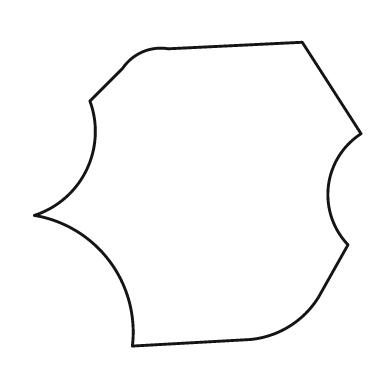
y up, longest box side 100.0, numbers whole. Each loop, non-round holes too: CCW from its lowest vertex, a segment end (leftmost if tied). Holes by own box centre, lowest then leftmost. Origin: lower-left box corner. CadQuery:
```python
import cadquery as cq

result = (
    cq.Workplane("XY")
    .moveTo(30.0, 0.0)
    .lineTo(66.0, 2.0)
    .threePointArc((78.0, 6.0), (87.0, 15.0))
    .lineTo(96.0, 31.0)
    .threePointArc((90.0, 49.0), (100.0, 65.0))
    .lineTo(82.0, 93.0)
    .lineTo(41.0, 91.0)
    .threePointArc((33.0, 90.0), (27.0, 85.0))
    .lineTo(17.0, 75.0)
    .threePointArc((16.0, 54.0), (0.0, 40.0))
    .threePointArc((23.0, 26.0), (30.0, 0.0))
    .close()
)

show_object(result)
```